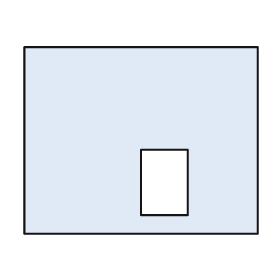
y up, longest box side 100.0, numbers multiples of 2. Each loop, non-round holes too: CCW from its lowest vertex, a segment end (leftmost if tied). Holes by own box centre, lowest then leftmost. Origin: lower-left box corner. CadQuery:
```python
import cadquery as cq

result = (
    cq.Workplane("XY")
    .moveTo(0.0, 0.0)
    .lineTo(100.0, 0.0)
    .lineTo(100.0, 80.0)
    .lineTo(0.0, 80.0)
    .close()
    .moveTo(50.0, 8.0)
    .lineTo(70.0, 8.0)
    .lineTo(70.0, 36.0)
    .lineTo(50.0, 36.0)
    .close()
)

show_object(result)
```